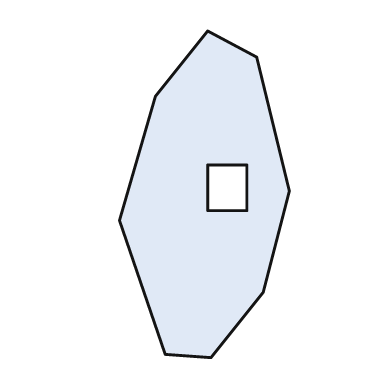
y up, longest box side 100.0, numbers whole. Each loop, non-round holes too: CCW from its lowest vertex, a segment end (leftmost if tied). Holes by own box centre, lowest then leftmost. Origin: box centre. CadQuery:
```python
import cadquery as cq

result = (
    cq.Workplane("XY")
    .moveTo(2.0, -50.0)
    .lineTo(18.0, -30.0)
    .lineTo(26.0, 1.0)
    .lineTo(16.0, 42.0)
    .lineTo(1.0, 50.0)
    .lineTo(-15.0, 30.0)
    .lineTo(-26.0, -8.0)
    .lineTo(-12.0, -49.0)
    .close()
    .moveTo(1.0, -5.0)
    .lineTo(13.0, -5.0)
    .lineTo(13.0, 9.0)
    .lineTo(1.0, 9.0)
    .close()
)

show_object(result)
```